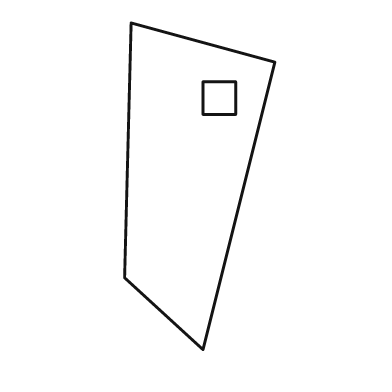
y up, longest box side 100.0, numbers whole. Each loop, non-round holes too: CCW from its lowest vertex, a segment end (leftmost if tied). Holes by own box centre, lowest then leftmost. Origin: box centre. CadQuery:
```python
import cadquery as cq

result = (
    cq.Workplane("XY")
    .moveTo(1.0, -50.0)
    .lineTo(23.0, 38.0)
    .lineTo(-21.0, 50.0)
    .lineTo(-23.0, -28.0)
    .close()
    .moveTo(1.0, 22.0)
    .lineTo(11.0, 22.0)
    .lineTo(11.0, 32.0)
    .lineTo(1.0, 32.0)
    .close()
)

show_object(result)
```